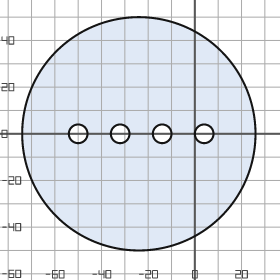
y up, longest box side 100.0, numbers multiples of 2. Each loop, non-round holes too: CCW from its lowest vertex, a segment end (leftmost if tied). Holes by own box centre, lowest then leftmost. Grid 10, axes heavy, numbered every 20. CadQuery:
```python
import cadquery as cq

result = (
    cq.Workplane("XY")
    .moveTo(-24.0, 0.0)
    .circle(50.0)
    .moveTo(-50.0, 0.0)
    .circle(4.0)
    .moveTo(-32.0, 0.0)
    .circle(4.0)
    .moveTo(-14.0, 0.0)
    .circle(4.0)
    .moveTo(4.0, 0.0)
    .circle(4.0)
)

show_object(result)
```